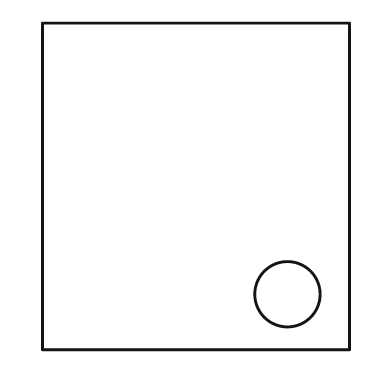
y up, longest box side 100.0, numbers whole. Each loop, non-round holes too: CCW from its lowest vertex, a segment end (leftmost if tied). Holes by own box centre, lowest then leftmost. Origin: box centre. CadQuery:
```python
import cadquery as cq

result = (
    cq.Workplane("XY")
    .moveTo(-47.0, -50.0)
    .lineTo(47.0, -50.0)
    .lineTo(47.0, 50.0)
    .lineTo(-47.0, 50.0)
    .close()
    .moveTo(28.0, -33.0)
    .circle(10.0)
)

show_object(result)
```